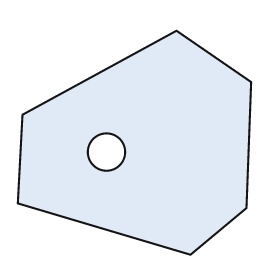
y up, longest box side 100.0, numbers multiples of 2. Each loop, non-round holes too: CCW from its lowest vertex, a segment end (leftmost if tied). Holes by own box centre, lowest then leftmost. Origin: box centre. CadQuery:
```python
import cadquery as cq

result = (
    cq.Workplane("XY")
    .moveTo(24.0, -48.0)
    .lineTo(48.0, -28.0)
    .lineTo(50.0, 26.0)
    .lineTo(18.0, 48.0)
    .lineTo(-48.0, 12.0)
    .lineTo(-50.0, -26.0)
    .close()
    .moveTo(-12.0, -4.0)
    .circle(8.0)
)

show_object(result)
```